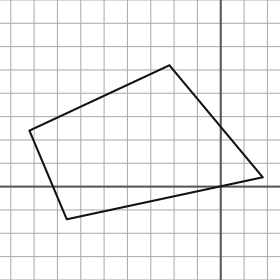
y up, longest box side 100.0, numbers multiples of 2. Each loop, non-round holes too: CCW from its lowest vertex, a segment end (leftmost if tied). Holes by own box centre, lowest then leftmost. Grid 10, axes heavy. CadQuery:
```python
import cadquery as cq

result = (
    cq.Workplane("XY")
    .moveTo(-66.0, -14.0)
    .lineTo(18.0, 4.0)
    .lineTo(-22.0, 52.0)
    .lineTo(-82.0, 24.0)
    .close()
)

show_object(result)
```